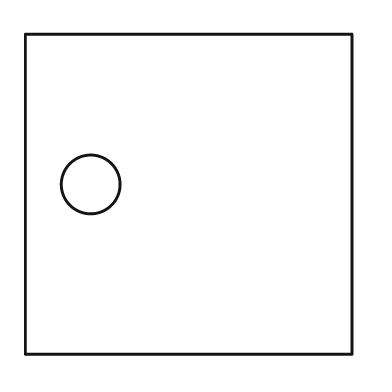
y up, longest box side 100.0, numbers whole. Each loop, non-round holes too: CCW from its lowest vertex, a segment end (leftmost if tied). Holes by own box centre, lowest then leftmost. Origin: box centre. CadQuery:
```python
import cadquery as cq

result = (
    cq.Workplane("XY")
    .moveTo(-50.0, -49.0)
    .lineTo(50.0, -49.0)
    .lineTo(50.0, 49.0)
    .lineTo(-50.0, 49.0)
    .close()
    .moveTo(-30.0, 3.0)
    .circle(9.0)
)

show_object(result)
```